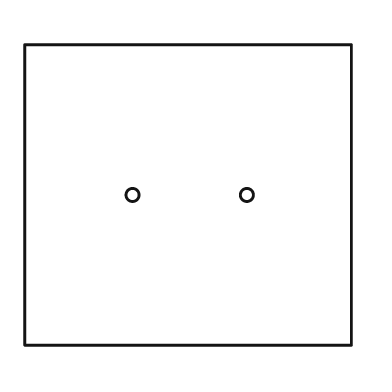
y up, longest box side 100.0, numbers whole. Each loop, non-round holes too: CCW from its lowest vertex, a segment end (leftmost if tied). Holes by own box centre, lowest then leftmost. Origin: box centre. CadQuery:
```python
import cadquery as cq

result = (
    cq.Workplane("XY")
    .moveTo(-50.0, -46.0)
    .lineTo(50.0, -46.0)
    .lineTo(50.0, 46.0)
    .lineTo(-50.0, 46.0)
    .close()
    .moveTo(-17.0, 0.0)
    .circle(2.0)
    .moveTo(18.0, 0.0)
    .circle(2.0)
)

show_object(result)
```